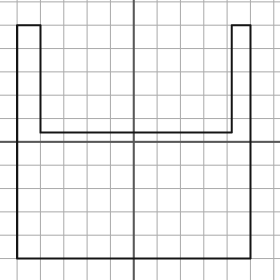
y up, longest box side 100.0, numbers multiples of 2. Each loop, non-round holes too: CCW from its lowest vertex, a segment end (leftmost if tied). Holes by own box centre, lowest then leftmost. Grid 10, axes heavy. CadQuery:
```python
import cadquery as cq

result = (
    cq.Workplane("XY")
    .moveTo(-50.0, -50.0)
    .lineTo(50.0, -50.0)
    .lineTo(50.0, 50.0)
    .lineTo(42.0, 50.0)
    .lineTo(42.0, 4.0)
    .lineTo(-40.0, 4.0)
    .lineTo(-40.0, 50.0)
    .lineTo(-50.0, 50.0)
    .close()
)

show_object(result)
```